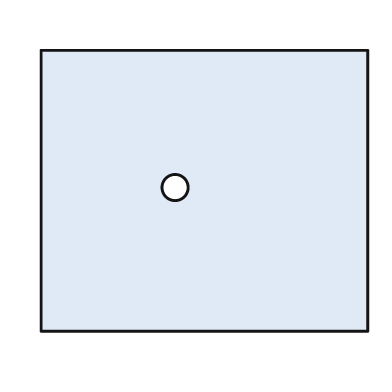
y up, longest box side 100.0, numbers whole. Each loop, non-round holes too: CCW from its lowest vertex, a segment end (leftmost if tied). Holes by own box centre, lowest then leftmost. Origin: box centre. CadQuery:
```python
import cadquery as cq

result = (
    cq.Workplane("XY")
    .moveTo(-50.0, -43.0)
    .lineTo(50.0, -43.0)
    .lineTo(50.0, 43.0)
    .lineTo(-50.0, 43.0)
    .close()
    .moveTo(-9.0, 1.0)
    .circle(4.0)
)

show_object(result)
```